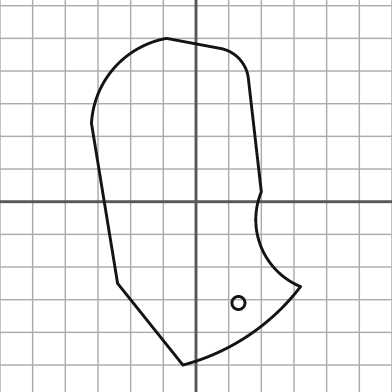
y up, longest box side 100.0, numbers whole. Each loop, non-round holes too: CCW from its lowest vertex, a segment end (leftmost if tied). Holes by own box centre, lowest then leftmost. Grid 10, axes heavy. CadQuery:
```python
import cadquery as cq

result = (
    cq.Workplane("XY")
    .moveTo(-4.0, -50.0)
    .threePointArc((16.0, -41.0), (32.0, -26.0))
    .threePointArc((20.0, -14.0), (20.0, 3.0))
    .lineTo(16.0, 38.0)
    .threePointArc((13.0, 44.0), (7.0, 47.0))
    .lineTo(-9.0, 50.0)
    .threePointArc((-25.0, 41.0), (-32.0, 24.0))
    .lineTo(-24.0, -25.0)
    .close()
    .moveTo(13.0, -31.0)
    .circle(2.0)
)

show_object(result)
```